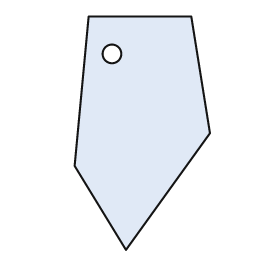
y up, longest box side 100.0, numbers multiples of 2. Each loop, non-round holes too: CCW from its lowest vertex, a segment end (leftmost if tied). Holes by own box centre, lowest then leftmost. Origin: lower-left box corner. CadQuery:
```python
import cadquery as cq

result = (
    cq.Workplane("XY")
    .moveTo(22.0, 0.0)
    .lineTo(58.0, 50.0)
    .lineTo(50.0, 100.0)
    .lineTo(6.0, 100.0)
    .lineTo(0.0, 36.0)
    .close()
    .moveTo(16.0, 84.0)
    .circle(4.0)
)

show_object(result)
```